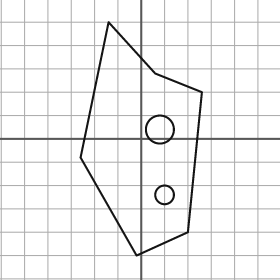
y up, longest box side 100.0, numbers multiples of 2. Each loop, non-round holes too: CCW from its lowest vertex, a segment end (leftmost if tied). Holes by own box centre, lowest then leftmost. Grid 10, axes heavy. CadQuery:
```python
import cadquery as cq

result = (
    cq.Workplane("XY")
    .moveTo(-2.0, -50.0)
    .lineTo(20.0, -40.0)
    .lineTo(26.0, 20.0)
    .lineTo(6.0, 28.0)
    .lineTo(-14.0, 50.0)
    .lineTo(-26.0, -8.0)
    .close()
    .moveTo(10.0, -24.0)
    .circle(4.0)
    .moveTo(8.0, 4.0)
    .circle(6.0)
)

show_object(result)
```